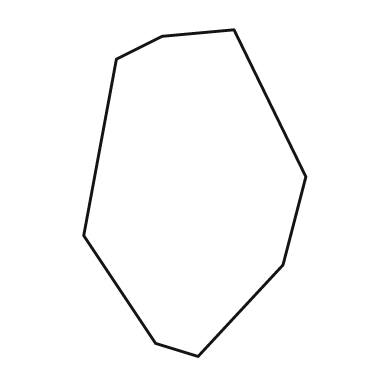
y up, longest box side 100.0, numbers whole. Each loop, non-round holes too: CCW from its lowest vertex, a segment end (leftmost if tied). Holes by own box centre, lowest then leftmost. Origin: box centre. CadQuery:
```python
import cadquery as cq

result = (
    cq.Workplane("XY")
    .moveTo(1.0, -50.0)
    .lineTo(27.0, -22.0)
    .lineTo(34.0, 5.0)
    .lineTo(12.0, 50.0)
    .lineTo(-10.0, 48.0)
    .lineTo(-24.0, 41.0)
    .lineTo(-34.0, -13.0)
    .lineTo(-12.0, -46.0)
    .close()
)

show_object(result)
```